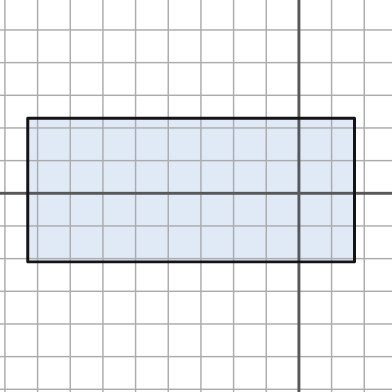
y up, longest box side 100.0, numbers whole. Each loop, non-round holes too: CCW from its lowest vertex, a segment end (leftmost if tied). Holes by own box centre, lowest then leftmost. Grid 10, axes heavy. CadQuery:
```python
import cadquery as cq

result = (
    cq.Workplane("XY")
    .moveTo(-83.0, -21.0)
    .lineTo(17.0, -21.0)
    .lineTo(17.0, 23.0)
    .lineTo(-83.0, 23.0)
    .close()
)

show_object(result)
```